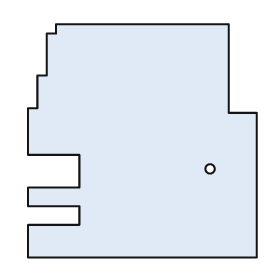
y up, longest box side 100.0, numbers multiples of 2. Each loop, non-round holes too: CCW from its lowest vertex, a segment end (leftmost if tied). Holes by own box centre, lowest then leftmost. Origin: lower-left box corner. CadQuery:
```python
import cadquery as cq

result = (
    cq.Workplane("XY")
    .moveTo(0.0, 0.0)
    .lineTo(98.0, 0.0)
    .lineTo(98.0, 62.0)
    .lineTo(86.0, 62.0)
    .lineTo(86.0, 100.0)
    .lineTo(12.0, 100.0)
    .lineTo(12.0, 96.0)
    .lineTo(8.0, 96.0)
    .lineTo(8.0, 78.0)
    .lineTo(4.0, 78.0)
    .lineTo(4.0, 64.0)
    .lineTo(0.0, 64.0)
    .lineTo(0.0, 44.0)
    .lineTo(22.0, 44.0)
    .lineTo(22.0, 30.0)
    .lineTo(0.0, 30.0)
    .lineTo(0.0, 22.0)
    .lineTo(22.0, 22.0)
    .lineTo(22.0, 14.0)
    .lineTo(0.0, 14.0)
    .close()
    .moveTo(78.0, 38.0)
    .circle(2.0)
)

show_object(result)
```